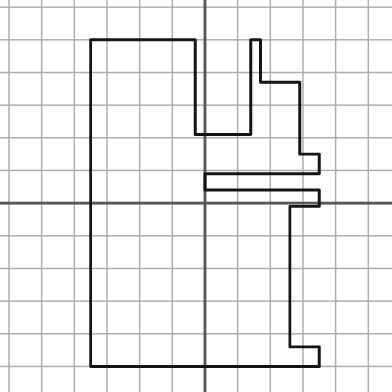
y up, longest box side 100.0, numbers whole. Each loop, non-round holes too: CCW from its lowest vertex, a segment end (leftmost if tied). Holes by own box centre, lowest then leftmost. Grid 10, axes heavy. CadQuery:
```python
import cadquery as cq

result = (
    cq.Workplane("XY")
    .moveTo(-35.0, -50.0)
    .lineTo(35.0, -50.0)
    .lineTo(35.0, -44.0)
    .lineTo(26.0, -44.0)
    .lineTo(26.0, -1.0)
    .lineTo(35.0, -1.0)
    .lineTo(35.0, 4.0)
    .lineTo(0.0, 4.0)
    .lineTo(0.0, 9.0)
    .lineTo(35.0, 9.0)
    .lineTo(35.0, 15.0)
    .lineTo(29.0, 15.0)
    .lineTo(29.0, 37.0)
    .lineTo(17.0, 37.0)
    .lineTo(17.0, 50.0)
    .lineTo(14.0, 50.0)
    .lineTo(14.0, 21.0)
    .lineTo(-3.0, 21.0)
    .lineTo(-3.0, 50.0)
    .lineTo(-35.0, 50.0)
    .close()
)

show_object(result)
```